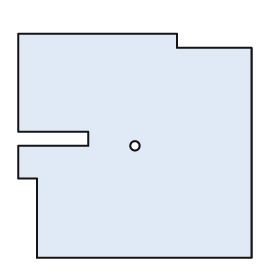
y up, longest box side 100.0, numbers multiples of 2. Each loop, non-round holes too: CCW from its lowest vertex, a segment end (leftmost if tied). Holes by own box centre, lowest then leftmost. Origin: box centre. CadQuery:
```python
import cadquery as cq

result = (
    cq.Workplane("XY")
    .moveTo(-42.0, -48.0)
    .lineTo(50.0, -48.0)
    .lineTo(50.0, 42.0)
    .lineTo(18.0, 42.0)
    .lineTo(18.0, 48.0)
    .lineTo(-50.0, 48.0)
    .lineTo(-50.0, 6.0)
    .lineTo(-20.0, 6.0)
    .lineTo(-20.0, 0.0)
    .lineTo(-50.0, 0.0)
    .lineTo(-50.0, -14.0)
    .lineTo(-42.0, -14.0)
    .close()
    .moveTo(0.0, 0.0)
    .circle(2.0)
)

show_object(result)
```